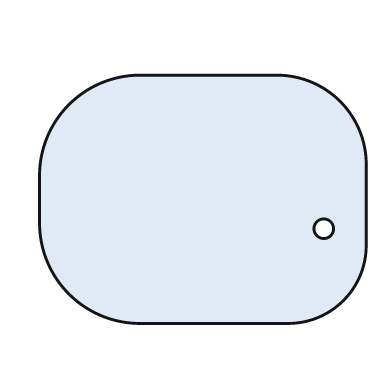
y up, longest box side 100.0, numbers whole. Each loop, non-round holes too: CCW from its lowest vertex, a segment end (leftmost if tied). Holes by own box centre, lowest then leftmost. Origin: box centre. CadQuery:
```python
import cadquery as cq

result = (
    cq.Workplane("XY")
    .moveTo(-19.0, -38.0)
    .lineTo(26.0, -38.0)
    .threePointArc((43.0, -31.0), (50.0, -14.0))
    .lineTo(50.0, 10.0)
    .threePointArc((42.0, 30.0), (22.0, 38.0))
    .lineTo(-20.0, 38.0)
    .threePointArc((-41.0, 29.0), (-50.0, 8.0))
    .lineTo(-50.0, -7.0)
    .threePointArc((-41.0, -29.0), (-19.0, -38.0))
    .close()
    .moveTo(37.0, -9.0)
    .circle(3.0)
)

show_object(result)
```